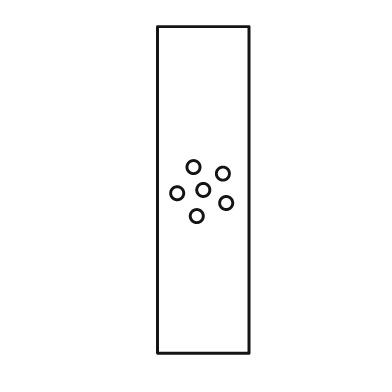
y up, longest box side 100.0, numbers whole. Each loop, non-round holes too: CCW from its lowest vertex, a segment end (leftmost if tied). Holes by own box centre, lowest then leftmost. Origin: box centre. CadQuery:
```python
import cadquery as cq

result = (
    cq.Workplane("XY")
    .moveTo(-14.0, -50.0)
    .lineTo(14.0, -50.0)
    .lineTo(14.0, 50.0)
    .lineTo(-14.0, 50.0)
    .close()
    .moveTo(-2.0, -8.0)
    .circle(2.0)
    .moveTo(7.0, -4.0)
    .circle(2.0)
    .moveTo(-8.0, -1.0)
    .circle(2.0)
    .moveTo(0.0, 0.0)
    .circle(2.0)
    .moveTo(6.0, 5.0)
    .circle(2.0)
    .moveTo(-3.0, 7.0)
    .circle(2.0)
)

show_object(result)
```